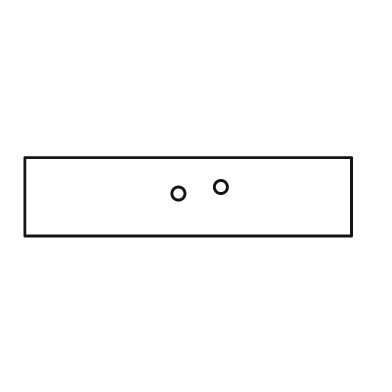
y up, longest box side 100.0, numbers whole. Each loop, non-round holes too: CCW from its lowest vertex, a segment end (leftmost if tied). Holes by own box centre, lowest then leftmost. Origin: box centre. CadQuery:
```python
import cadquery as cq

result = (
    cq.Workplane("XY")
    .moveTo(-50.0, -12.0)
    .lineTo(50.0, -12.0)
    .lineTo(50.0, 12.0)
    .lineTo(-50.0, 12.0)
    .close()
    .moveTo(-3.0, 1.0)
    .circle(2.0)
    .moveTo(10.0, 3.0)
    .circle(2.0)
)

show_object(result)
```